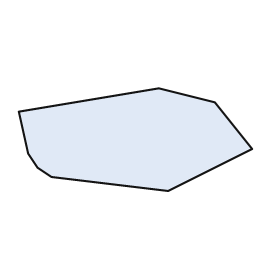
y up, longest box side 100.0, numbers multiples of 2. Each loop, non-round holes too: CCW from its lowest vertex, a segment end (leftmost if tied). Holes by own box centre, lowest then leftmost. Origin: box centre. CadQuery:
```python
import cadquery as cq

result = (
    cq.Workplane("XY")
    .moveTo(14.0, -22.0)
    .lineTo(50.0, -4.0)
    .lineTo(34.0, 16.0)
    .lineTo(10.0, 22.0)
    .lineTo(-50.0, 12.0)
    .lineTo(-46.0, -6.0)
    .lineTo(-42.0, -12.0)
    .lineTo(-36.0, -16.0)
    .close()
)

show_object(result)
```